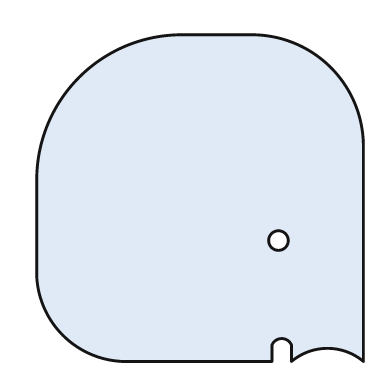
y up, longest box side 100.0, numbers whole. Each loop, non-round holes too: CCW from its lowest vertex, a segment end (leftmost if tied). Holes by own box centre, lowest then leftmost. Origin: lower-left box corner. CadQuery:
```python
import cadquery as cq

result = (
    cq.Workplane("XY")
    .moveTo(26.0, 0.0)
    .lineTo(72.0, 0.0)
    .lineTo(72.0, 5.0)
    .threePointArc((75.0, 7.0), (78.0, 5.0))
    .lineTo(78.0, 0.0)
    .threePointArc((89.0, 4.0), (100.0, 0.0))
    .lineTo(100.0, 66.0)
    .threePointArc((90.0, 90.0), (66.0, 100.0))
    .lineTo(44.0, 100.0)
    .threePointArc((13.0, 87.0), (0.0, 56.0))
    .lineTo(0.0, 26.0)
    .threePointArc((8.0, 8.0), (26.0, 0.0))
    .close()
    .moveTo(74.0, 37.0)
    .circle(3.0)
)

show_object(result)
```